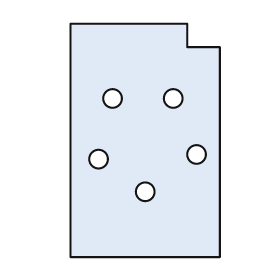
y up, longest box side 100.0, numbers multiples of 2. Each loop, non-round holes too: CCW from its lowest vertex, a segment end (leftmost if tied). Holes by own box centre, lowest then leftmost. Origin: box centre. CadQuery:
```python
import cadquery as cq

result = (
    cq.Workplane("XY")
    .moveTo(-32.0, -50.0)
    .lineTo(32.0, -50.0)
    .lineTo(32.0, 40.0)
    .lineTo(18.0, 40.0)
    .lineTo(18.0, 50.0)
    .lineTo(-32.0, 50.0)
    .close()
    .moveTo(0.0, -22.0)
    .circle(4.0)
    .moveTo(-20.0, -8.0)
    .circle(4.0)
    .moveTo(22.0, -6.0)
    .circle(4.0)
    .moveTo(-14.0, 18.0)
    .circle(4.0)
    .moveTo(12.0, 18.0)
    .circle(4.0)
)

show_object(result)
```